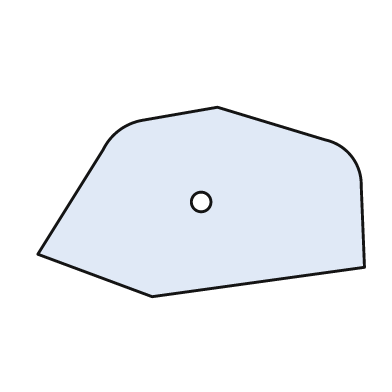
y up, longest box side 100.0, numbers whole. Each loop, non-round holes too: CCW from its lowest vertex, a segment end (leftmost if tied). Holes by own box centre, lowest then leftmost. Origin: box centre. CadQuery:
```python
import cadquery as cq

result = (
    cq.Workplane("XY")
    .moveTo(-15.0, -29.0)
    .lineTo(50.0, -20.0)
    .lineTo(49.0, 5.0)
    .threePointArc((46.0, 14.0), (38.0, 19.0))
    .lineTo(5.0, 29.0)
    .lineTo(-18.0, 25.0)
    .threePointArc((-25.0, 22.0), (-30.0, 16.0))
    .lineTo(-50.0, -16.0)
    .close()
    .moveTo(0.0, 0.0)
    .circle(3.0)
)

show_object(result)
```